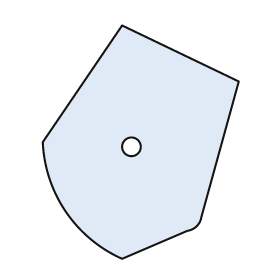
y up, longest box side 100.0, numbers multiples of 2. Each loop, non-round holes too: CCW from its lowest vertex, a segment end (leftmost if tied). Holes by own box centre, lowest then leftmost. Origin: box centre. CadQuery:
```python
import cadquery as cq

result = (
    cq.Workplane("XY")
    .moveTo(-8.0, -50.0)
    .lineTo(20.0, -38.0)
    .threePointArc((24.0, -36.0), (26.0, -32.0))
    .lineTo(42.0, 26.0)
    .lineTo(-8.0, 50.0)
    .lineTo(-42.0, 0.0)
    .threePointArc((-32.0, -30.0), (-8.0, -50.0))
    .close()
    .moveTo(-4.0, -2.0)
    .circle(4.0)
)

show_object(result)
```